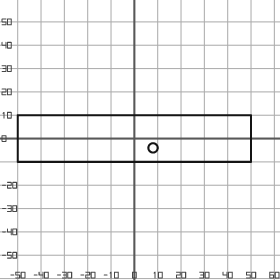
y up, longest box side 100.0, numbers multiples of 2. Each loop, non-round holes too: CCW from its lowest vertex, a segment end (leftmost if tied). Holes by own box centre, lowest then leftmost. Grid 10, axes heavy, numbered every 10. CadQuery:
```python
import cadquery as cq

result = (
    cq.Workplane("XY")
    .moveTo(-50.0, -10.0)
    .lineTo(50.0, -10.0)
    .lineTo(50.0, 10.0)
    .lineTo(-50.0, 10.0)
    .close()
    .moveTo(8.0, -4.0)
    .circle(2.0)
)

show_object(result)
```